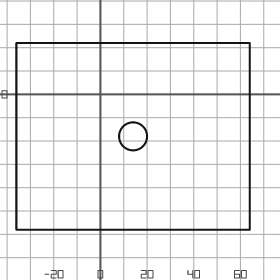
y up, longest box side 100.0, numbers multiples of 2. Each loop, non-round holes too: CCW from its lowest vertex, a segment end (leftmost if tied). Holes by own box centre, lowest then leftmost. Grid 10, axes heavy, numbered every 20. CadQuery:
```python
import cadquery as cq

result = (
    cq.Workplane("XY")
    .moveTo(-36.0, -58.0)
    .lineTo(64.0, -58.0)
    .lineTo(64.0, 22.0)
    .lineTo(-36.0, 22.0)
    .close()
    .moveTo(14.0, -18.0)
    .circle(6.0)
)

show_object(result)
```